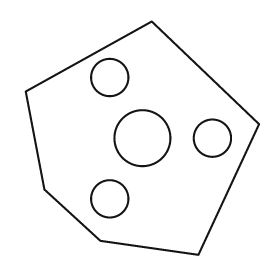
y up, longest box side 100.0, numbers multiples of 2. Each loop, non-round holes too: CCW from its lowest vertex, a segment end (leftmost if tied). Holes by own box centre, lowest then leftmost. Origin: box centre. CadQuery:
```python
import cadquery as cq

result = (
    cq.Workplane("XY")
    .moveTo(24.0, -50.0)
    .lineTo(50.0, 6.0)
    .lineTo(4.0, 50.0)
    .lineTo(-50.0, 20.0)
    .lineTo(-42.0, -22.0)
    .lineTo(-18.0, -44.0)
    .close()
    .moveTo(-14.0, -26.0)
    .circle(8.0)
    .moveTo(0.0, 0.0)
    .circle(12.0)
    .moveTo(30.0, 0.0)
    .circle(8.0)
    .moveTo(-14.0, 26.0)
    .circle(8.0)
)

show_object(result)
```